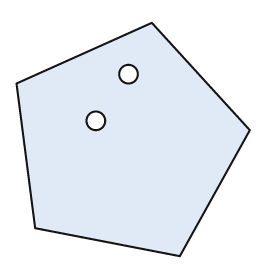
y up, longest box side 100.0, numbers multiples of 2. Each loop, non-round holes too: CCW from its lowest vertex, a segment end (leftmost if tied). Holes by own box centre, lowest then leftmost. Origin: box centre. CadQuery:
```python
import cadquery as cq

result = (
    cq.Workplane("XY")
    .moveTo(20.0, -50.0)
    .lineTo(50.0, 4.0)
    .lineTo(8.0, 50.0)
    .lineTo(-50.0, 24.0)
    .lineTo(-42.0, -38.0)
    .close()
    .moveTo(-16.0, 8.0)
    .circle(4.0)
    .moveTo(-2.0, 28.0)
    .circle(4.0)
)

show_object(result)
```